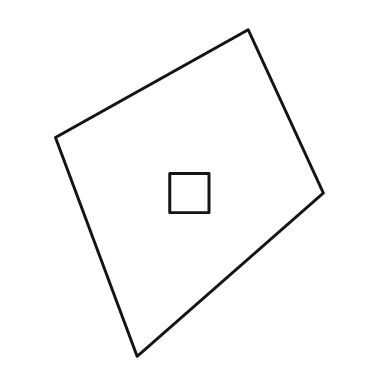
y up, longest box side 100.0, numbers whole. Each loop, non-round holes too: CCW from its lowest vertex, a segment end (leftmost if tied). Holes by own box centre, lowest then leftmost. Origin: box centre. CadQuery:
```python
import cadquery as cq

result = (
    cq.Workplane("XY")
    .moveTo(-16.0, -50.0)
    .lineTo(41.0, 0.0)
    .lineTo(18.0, 50.0)
    .lineTo(-41.0, 17.0)
    .close()
    .moveTo(-6.0, -6.0)
    .lineTo(6.0, -6.0)
    .lineTo(6.0, 6.0)
    .lineTo(-6.0, 6.0)
    .close()
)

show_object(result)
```